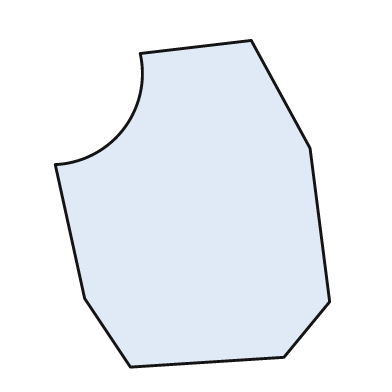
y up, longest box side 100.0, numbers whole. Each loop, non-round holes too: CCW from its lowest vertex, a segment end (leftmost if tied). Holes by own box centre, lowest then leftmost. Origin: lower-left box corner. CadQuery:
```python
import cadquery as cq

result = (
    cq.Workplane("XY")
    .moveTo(23.0, 0.0)
    .lineTo(70.0, 3.0)
    .lineTo(84.0, 20.0)
    .lineTo(78.0, 67.0)
    .lineTo(60.0, 100.0)
    .lineTo(26.0, 96.0)
    .threePointArc((21.0, 73.0), (0.0, 62.0))
    .lineTo(9.0, 21.0)
    .close()
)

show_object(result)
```